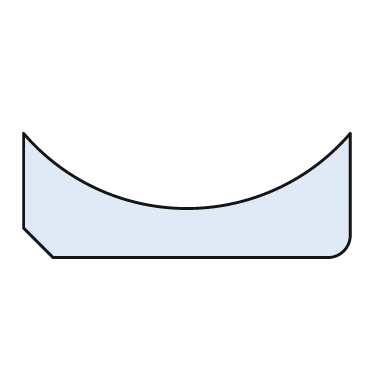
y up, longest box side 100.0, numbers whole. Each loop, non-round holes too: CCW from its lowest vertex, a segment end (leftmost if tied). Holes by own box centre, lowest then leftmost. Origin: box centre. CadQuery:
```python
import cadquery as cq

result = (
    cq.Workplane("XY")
    .moveTo(-41.0, -19.0)
    .lineTo(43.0, -19.0)
    .threePointArc((48.0, -17.0), (50.0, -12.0))
    .lineTo(50.0, 19.0)
    .threePointArc((0.0, -4.0), (-50.0, 19.0))
    .lineTo(-50.0, -10.0)
    .close()
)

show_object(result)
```